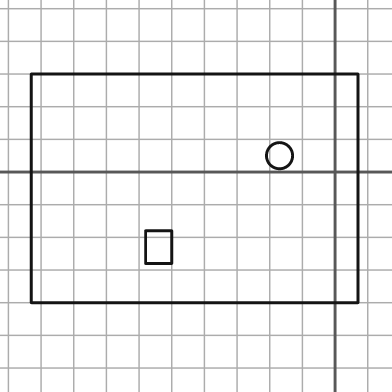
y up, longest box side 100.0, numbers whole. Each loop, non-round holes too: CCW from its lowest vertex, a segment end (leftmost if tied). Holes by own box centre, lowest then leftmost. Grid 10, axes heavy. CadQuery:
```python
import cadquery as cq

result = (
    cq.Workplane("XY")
    .moveTo(-93.0, -40.0)
    .lineTo(7.0, -40.0)
    .lineTo(7.0, 30.0)
    .lineTo(-93.0, 30.0)
    .close()
    .moveTo(-58.0, -28.0)
    .lineTo(-50.0, -28.0)
    .lineTo(-50.0, -18.0)
    .lineTo(-58.0, -18.0)
    .close()
    .moveTo(-17.0, 5.0)
    .circle(4.0)
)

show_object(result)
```